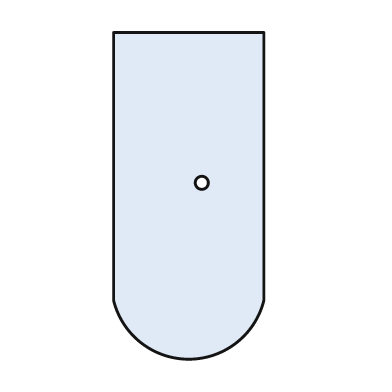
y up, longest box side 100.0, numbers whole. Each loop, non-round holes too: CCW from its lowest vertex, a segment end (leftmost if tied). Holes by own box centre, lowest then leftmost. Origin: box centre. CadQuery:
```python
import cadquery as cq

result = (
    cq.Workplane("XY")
    .moveTo(-23.0, -32.0)
    .threePointArc((0.0, -50.0), (23.0, -32.0))
    .lineTo(23.0, 50.0)
    .lineTo(-23.0, 50.0)
    .close()
    .moveTo(4.0, 4.0)
    .circle(2.0)
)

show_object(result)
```